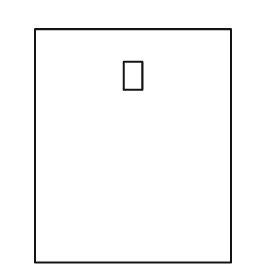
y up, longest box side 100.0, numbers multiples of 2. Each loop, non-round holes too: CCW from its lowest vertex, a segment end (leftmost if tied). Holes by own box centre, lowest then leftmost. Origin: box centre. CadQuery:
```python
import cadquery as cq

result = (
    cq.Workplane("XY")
    .moveTo(-42.0, -50.0)
    .lineTo(42.0, -50.0)
    .lineTo(42.0, 50.0)
    .lineTo(-42.0, 50.0)
    .close()
    .moveTo(-4.0, 24.0)
    .lineTo(4.0, 24.0)
    .lineTo(4.0, 36.0)
    .lineTo(-4.0, 36.0)
    .close()
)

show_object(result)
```